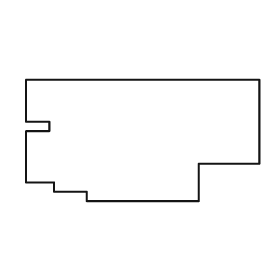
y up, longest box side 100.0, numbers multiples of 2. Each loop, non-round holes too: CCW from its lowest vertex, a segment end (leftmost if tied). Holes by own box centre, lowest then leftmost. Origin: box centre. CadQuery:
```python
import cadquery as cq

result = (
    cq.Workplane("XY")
    .moveTo(-24.0, -26.0)
    .lineTo(24.0, -26.0)
    .lineTo(24.0, -10.0)
    .lineTo(50.0, -10.0)
    .lineTo(50.0, 26.0)
    .lineTo(-50.0, 26.0)
    .lineTo(-50.0, 8.0)
    .lineTo(-40.0, 8.0)
    .lineTo(-40.0, 4.0)
    .lineTo(-50.0, 4.0)
    .lineTo(-50.0, -18.0)
    .lineTo(-38.0, -18.0)
    .lineTo(-38.0, -22.0)
    .lineTo(-24.0, -22.0)
    .close()
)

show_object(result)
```